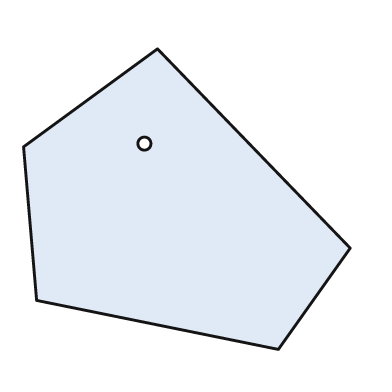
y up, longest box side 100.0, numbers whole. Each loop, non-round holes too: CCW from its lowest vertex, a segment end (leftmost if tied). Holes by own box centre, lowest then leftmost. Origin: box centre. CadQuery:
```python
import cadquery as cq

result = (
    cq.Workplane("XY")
    .moveTo(28.0, -46.0)
    .lineTo(50.0, -15.0)
    .lineTo(-9.0, 46.0)
    .lineTo(-50.0, 16.0)
    .lineTo(-46.0, -31.0)
    .close()
    .moveTo(-13.0, 17.0)
    .circle(2.0)
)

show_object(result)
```